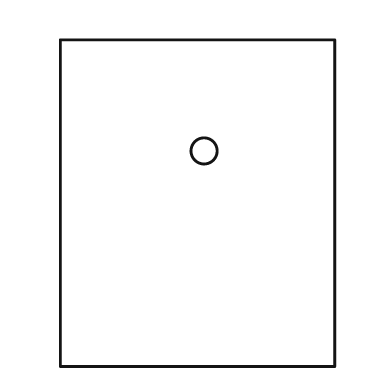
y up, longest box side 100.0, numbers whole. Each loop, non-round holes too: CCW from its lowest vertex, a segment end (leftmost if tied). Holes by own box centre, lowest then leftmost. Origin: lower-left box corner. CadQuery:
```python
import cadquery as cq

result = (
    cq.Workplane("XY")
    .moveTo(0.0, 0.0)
    .lineTo(84.0, 0.0)
    .lineTo(84.0, 100.0)
    .lineTo(0.0, 100.0)
    .close()
    .moveTo(44.0, 66.0)
    .circle(4.0)
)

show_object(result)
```